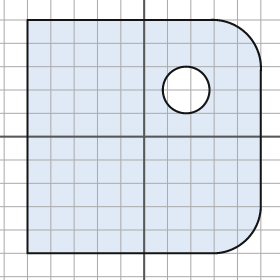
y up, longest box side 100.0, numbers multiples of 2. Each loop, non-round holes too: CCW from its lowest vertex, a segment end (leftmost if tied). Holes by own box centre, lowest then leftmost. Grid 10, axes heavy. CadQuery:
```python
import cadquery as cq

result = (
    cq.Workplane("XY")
    .moveTo(-50.0, -50.0)
    .lineTo(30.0, -50.0)
    .threePointArc((44.0, -44.0), (50.0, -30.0))
    .lineTo(50.0, 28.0)
    .threePointArc((44.0, 44.0), (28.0, 50.0))
    .lineTo(-50.0, 50.0)
    .close()
    .moveTo(18.0, 20.0)
    .circle(10.0)
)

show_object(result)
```